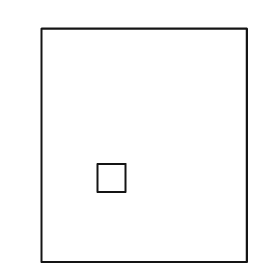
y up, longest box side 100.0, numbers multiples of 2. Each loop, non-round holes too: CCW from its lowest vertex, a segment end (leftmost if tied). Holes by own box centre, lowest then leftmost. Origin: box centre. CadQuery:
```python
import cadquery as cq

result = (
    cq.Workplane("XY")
    .moveTo(-44.0, -50.0)
    .lineTo(44.0, -50.0)
    .lineTo(44.0, 50.0)
    .lineTo(-44.0, 50.0)
    .close()
    .moveTo(-20.0, -20.0)
    .lineTo(-8.0, -20.0)
    .lineTo(-8.0, -8.0)
    .lineTo(-20.0, -8.0)
    .close()
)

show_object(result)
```